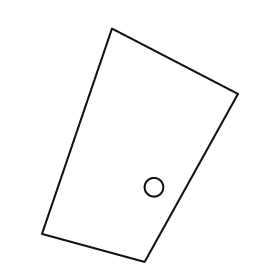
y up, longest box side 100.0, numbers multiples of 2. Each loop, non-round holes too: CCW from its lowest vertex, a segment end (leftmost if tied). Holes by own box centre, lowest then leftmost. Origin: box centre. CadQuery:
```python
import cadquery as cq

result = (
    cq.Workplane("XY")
    .moveTo(2.0, -50.0)
    .lineTo(42.0, 22.0)
    .lineTo(-12.0, 50.0)
    .lineTo(-42.0, -38.0)
    .close()
    .moveTo(6.0, -18.0)
    .circle(4.0)
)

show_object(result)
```